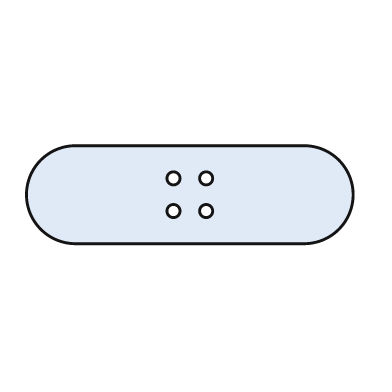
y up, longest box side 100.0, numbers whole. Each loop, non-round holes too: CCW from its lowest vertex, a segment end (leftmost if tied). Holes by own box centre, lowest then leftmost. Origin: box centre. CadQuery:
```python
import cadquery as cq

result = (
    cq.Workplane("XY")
    .moveTo(-35.0, -15.0)
    .lineTo(35.0, -15.0)
    .threePointArc((50.0, 0.0), (35.0, 15.0))
    .lineTo(-35.0, 15.0)
    .threePointArc((-50.0, 0.0), (-35.0, -15.0))
    .close()
    .moveTo(-5.0, -5.0)
    .circle(2.0)
    .moveTo(5.0, -5.0)
    .circle(2.0)
    .moveTo(-5.0, 5.0)
    .circle(2.0)
    .moveTo(5.0, 5.0)
    .circle(2.0)
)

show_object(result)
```